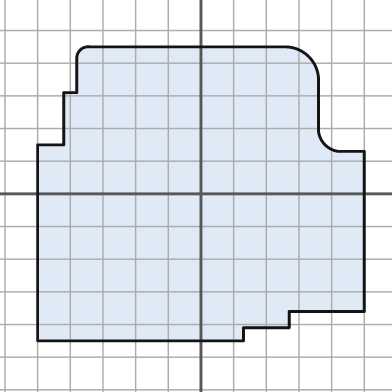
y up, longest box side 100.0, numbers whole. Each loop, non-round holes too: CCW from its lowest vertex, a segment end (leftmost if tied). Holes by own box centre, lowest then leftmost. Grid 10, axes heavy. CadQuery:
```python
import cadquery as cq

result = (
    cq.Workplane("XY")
    .moveTo(-50.0, -45.0)
    .lineTo(13.0, -45.0)
    .lineTo(13.0, -41.0)
    .lineTo(27.0, -41.0)
    .lineTo(27.0, -36.0)
    .lineTo(50.0, -36.0)
    .lineTo(50.0, 13.0)
    .lineTo(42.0, 13.0)
    .threePointArc((38.0, 15.0), (36.0, 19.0))
    .lineTo(36.0, 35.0)
    .threePointArc((33.0, 42.0), (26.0, 45.0))
    .lineTo(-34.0, 45.0)
    .threePointArc((-37.0, 44.0), (-38.0, 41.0))
    .lineTo(-38.0, 31.0)
    .lineTo(-42.0, 31.0)
    .lineTo(-42.0, 15.0)
    .lineTo(-50.0, 15.0)
    .close()
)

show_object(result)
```